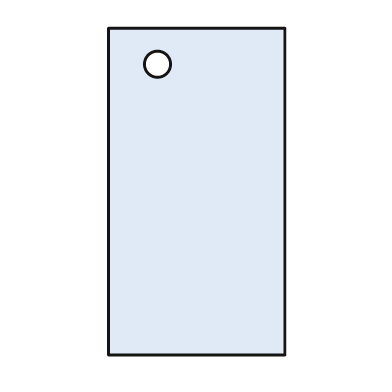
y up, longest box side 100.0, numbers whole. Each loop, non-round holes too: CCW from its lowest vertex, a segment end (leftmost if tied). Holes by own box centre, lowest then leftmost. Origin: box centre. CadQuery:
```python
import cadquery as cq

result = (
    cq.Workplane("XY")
    .moveTo(-27.0, -50.0)
    .lineTo(27.0, -50.0)
    .lineTo(27.0, 50.0)
    .lineTo(-27.0, 50.0)
    .close()
    .moveTo(-12.0, 39.0)
    .circle(4.0)
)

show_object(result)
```